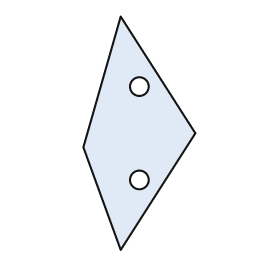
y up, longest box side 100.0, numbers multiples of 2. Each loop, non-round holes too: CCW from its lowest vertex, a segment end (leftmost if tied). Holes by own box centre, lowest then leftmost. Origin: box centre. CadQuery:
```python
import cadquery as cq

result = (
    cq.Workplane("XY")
    .moveTo(-8.0, -50.0)
    .lineTo(24.0, 0.0)
    .lineTo(-8.0, 50.0)
    .lineTo(-24.0, -6.0)
    .close()
    .moveTo(0.0, -20.0)
    .circle(4.0)
    .moveTo(0.0, 20.0)
    .circle(4.0)
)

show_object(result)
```